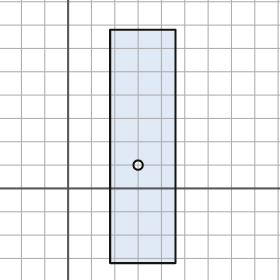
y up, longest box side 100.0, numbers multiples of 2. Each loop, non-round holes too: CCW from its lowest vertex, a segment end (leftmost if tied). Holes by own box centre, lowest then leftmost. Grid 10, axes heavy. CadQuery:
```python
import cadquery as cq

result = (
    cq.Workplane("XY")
    .moveTo(18.0, -32.0)
    .lineTo(46.0, -32.0)
    .lineTo(46.0, 68.0)
    .lineTo(18.0, 68.0)
    .close()
    .moveTo(30.0, 10.0)
    .circle(2.0)
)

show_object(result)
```